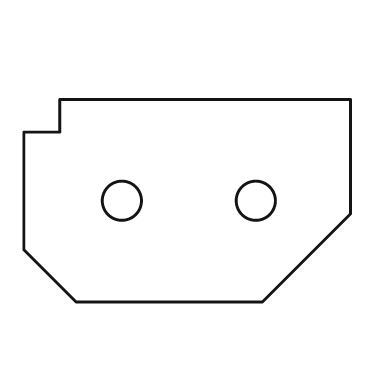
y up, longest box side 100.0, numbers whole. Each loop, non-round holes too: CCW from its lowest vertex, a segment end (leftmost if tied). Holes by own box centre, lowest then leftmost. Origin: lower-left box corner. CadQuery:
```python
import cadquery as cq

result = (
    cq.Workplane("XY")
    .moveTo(16.0, 0.0)
    .lineTo(73.0, 0.0)
    .lineTo(100.0, 27.0)
    .lineTo(100.0, 62.0)
    .lineTo(11.0, 62.0)
    .lineTo(11.0, 52.0)
    .lineTo(0.0, 52.0)
    .lineTo(0.0, 16.0)
    .close()
    .moveTo(30.0, 31.0)
    .circle(6.0)
    .moveTo(71.0, 31.0)
    .circle(6.0)
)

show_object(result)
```